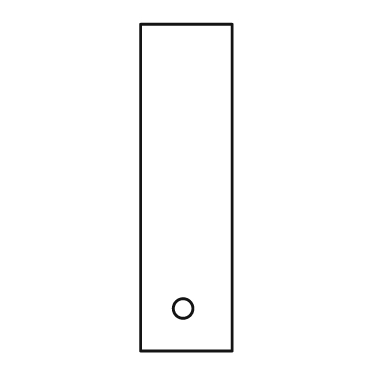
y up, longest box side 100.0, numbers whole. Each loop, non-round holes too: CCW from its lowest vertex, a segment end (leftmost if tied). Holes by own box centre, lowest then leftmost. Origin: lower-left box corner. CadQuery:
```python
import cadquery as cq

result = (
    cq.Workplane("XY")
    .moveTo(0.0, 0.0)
    .lineTo(28.0, 0.0)
    .lineTo(28.0, 100.0)
    .lineTo(0.0, 100.0)
    .close()
    .moveTo(13.0, 13.0)
    .circle(3.0)
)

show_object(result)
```